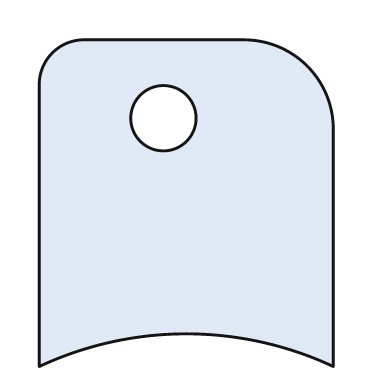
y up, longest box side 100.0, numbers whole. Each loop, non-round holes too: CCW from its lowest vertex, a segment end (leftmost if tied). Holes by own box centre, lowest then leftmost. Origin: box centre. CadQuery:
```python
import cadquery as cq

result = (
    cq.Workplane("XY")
    .moveTo(-45.0, -50.0)
    .threePointArc((0.0, -40.0), (45.0, -50.0))
    .lineTo(45.0, 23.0)
    .threePointArc((37.0, 42.0), (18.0, 50.0))
    .lineTo(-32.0, 50.0)
    .threePointArc((-41.0, 46.0), (-45.0, 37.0))
    .close()
    .moveTo(-7.0, 26.0)
    .circle(10.0)
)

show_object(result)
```